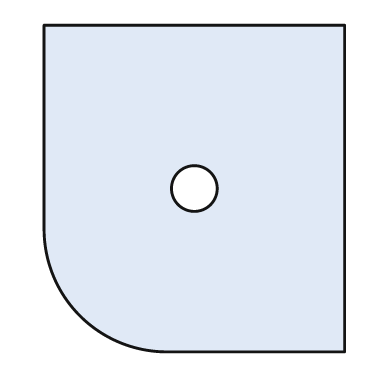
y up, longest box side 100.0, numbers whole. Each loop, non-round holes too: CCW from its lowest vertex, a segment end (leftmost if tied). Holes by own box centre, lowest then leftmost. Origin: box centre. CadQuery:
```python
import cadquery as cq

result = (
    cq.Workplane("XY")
    .moveTo(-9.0, -50.0)
    .lineTo(46.0, -50.0)
    .lineTo(46.0, 50.0)
    .lineTo(-46.0, 50.0)
    .lineTo(-46.0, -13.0)
    .threePointArc((-35.0, -39.0), (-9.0, -50.0))
    .close()
    .moveTo(0.0, 0.0)
    .circle(7.0)
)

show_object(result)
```